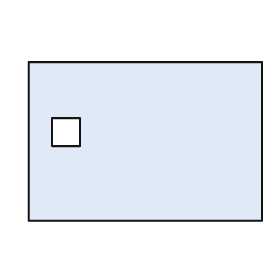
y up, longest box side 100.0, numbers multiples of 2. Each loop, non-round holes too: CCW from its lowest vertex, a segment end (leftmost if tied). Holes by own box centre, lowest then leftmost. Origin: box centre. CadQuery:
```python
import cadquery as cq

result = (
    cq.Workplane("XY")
    .moveTo(-50.0, -34.0)
    .lineTo(50.0, -34.0)
    .lineTo(50.0, 34.0)
    .lineTo(-50.0, 34.0)
    .close()
    .moveTo(-40.0, -2.0)
    .lineTo(-28.0, -2.0)
    .lineTo(-28.0, 10.0)
    .lineTo(-40.0, 10.0)
    .close()
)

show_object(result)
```